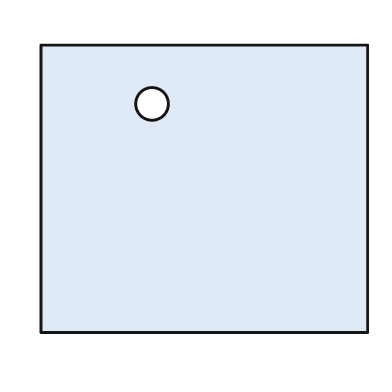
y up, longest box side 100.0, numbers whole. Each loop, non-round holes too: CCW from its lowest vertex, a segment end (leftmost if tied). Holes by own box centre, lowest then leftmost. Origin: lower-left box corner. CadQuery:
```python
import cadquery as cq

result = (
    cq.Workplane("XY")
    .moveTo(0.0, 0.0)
    .lineTo(100.0, 0.0)
    .lineTo(100.0, 88.0)
    .lineTo(0.0, 88.0)
    .close()
    .moveTo(34.0, 70.0)
    .circle(5.0)
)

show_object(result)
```